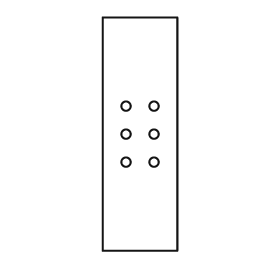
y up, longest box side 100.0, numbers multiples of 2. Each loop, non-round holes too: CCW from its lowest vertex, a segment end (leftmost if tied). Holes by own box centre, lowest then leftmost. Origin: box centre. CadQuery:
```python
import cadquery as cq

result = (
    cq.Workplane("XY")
    .moveTo(-16.0, -50.0)
    .lineTo(16.0, -50.0)
    .lineTo(16.0, 50.0)
    .lineTo(-16.0, 50.0)
    .close()
    .moveTo(-6.0, -12.0)
    .circle(2.0)
    .moveTo(6.0, -12.0)
    .circle(2.0)
    .moveTo(-6.0, 0.0)
    .circle(2.0)
    .moveTo(6.0, 0.0)
    .circle(2.0)
    .moveTo(-6.0, 12.0)
    .circle(2.0)
    .moveTo(6.0, 12.0)
    .circle(2.0)
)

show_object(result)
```